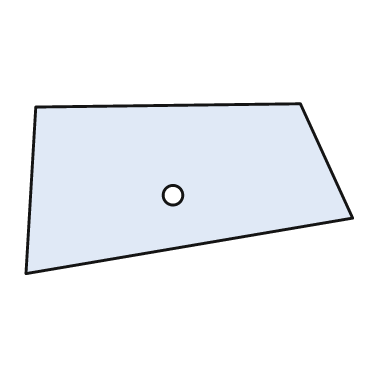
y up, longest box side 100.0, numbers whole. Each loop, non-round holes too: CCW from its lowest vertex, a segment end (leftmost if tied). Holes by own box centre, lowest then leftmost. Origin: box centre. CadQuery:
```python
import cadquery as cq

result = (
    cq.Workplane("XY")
    .moveTo(-50.0, -26.0)
    .lineTo(50.0, -9.0)
    .lineTo(34.0, 26.0)
    .lineTo(-47.0, 25.0)
    .close()
    .moveTo(-5.0, -2.0)
    .circle(3.0)
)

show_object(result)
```